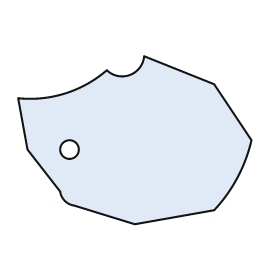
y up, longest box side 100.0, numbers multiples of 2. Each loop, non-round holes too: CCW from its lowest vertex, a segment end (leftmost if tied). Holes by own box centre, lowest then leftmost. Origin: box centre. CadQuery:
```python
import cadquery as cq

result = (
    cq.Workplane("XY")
    .moveTo(0.0, -36.0)
    .lineTo(34.0, -30.0)
    .threePointArc((44.0, -16.0), (50.0, 0.0))
    .lineTo(34.0, 24.0)
    .lineTo(4.0, 36.0)
    .threePointArc((-2.0, 28.0), (-12.0, 30.0))
    .threePointArc((-30.0, 20.0), (-50.0, 18.0))
    .lineTo(-46.0, -4.0)
    .lineTo(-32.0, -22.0)
    .threePointArc((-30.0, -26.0), (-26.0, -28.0))
    .close()
    .moveTo(-28.0, -4.0)
    .circle(4.0)
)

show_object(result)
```